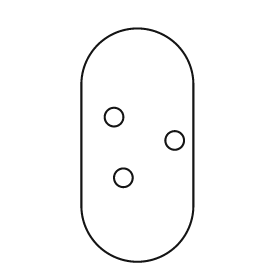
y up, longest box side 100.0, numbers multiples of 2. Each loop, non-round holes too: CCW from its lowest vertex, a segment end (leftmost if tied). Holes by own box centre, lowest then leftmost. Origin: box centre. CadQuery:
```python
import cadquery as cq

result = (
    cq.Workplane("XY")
    .moveTo(-24.0, -26.0)
    .threePointArc((0.0, -50.0), (24.0, -26.0))
    .lineTo(24.0, 26.0)
    .threePointArc((0.0, 50.0), (-24.0, 26.0))
    .close()
    .moveTo(-6.0, -14.0)
    .circle(4.0)
    .moveTo(16.0, 2.0)
    .circle(4.0)
    .moveTo(-10.0, 12.0)
    .circle(4.0)
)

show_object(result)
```